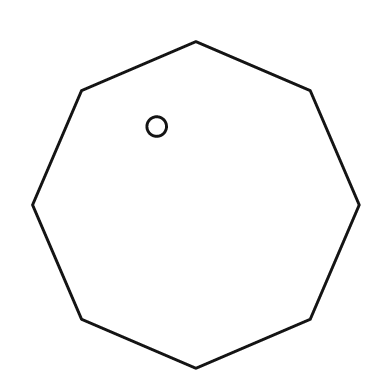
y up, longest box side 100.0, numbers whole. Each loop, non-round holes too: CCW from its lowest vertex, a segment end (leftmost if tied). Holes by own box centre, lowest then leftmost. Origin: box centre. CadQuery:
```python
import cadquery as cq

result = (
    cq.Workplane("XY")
    .moveTo(0.0, -50.0)
    .lineTo(35.0, -35.0)
    .lineTo(50.0, 0.0)
    .lineTo(35.0, 35.0)
    .lineTo(0.0, 50.0)
    .lineTo(-35.0, 35.0)
    .lineTo(-50.0, 0.0)
    .lineTo(-35.0, -35.0)
    .close()
    .moveTo(-12.0, 24.0)
    .circle(3.0)
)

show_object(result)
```